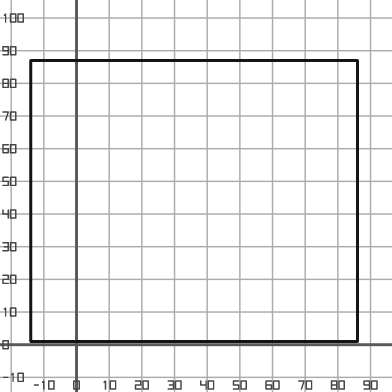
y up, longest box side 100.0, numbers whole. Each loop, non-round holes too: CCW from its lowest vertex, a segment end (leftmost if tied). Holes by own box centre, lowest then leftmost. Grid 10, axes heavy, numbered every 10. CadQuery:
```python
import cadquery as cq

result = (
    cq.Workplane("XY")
    .moveTo(-14.0, 1.0)
    .lineTo(86.0, 1.0)
    .lineTo(86.0, 87.0)
    .lineTo(-14.0, 87.0)
    .close()
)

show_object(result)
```